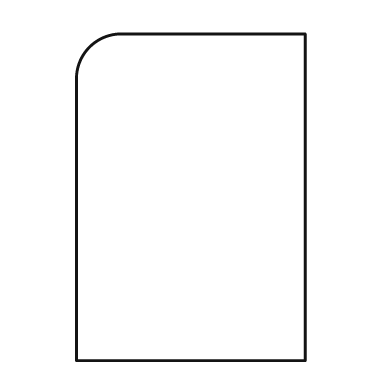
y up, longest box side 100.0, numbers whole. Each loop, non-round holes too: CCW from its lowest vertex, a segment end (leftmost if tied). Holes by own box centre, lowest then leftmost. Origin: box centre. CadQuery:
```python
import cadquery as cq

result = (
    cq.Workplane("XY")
    .moveTo(-35.0, -50.0)
    .lineTo(35.0, -50.0)
    .lineTo(35.0, 50.0)
    .lineTo(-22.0, 50.0)
    .threePointArc((-31.0, 46.0), (-35.0, 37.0))
    .close()
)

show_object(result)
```